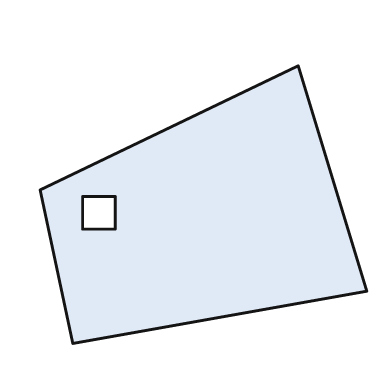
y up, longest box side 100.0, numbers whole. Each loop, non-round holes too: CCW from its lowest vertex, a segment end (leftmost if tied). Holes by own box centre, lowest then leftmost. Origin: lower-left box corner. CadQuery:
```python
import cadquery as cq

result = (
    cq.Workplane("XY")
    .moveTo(10.0, 0.0)
    .lineTo(100.0, 16.0)
    .lineTo(79.0, 85.0)
    .lineTo(0.0, 47.0)
    .close()
    .moveTo(13.0, 35.0)
    .lineTo(23.0, 35.0)
    .lineTo(23.0, 45.0)
    .lineTo(13.0, 45.0)
    .close()
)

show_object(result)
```